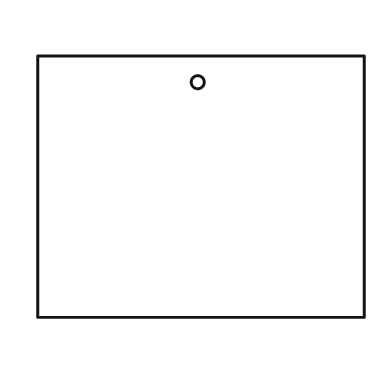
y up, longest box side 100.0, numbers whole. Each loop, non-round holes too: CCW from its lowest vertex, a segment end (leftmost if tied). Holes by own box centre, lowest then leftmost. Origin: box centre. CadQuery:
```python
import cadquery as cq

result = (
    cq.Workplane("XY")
    .moveTo(-50.0, -40.0)
    .lineTo(50.0, -40.0)
    .lineTo(50.0, 40.0)
    .lineTo(-50.0, 40.0)
    .close()
    .moveTo(-1.0, 32.0)
    .circle(2.0)
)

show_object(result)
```